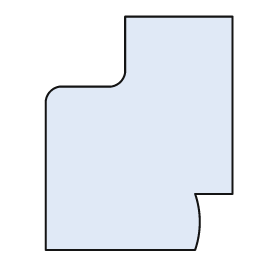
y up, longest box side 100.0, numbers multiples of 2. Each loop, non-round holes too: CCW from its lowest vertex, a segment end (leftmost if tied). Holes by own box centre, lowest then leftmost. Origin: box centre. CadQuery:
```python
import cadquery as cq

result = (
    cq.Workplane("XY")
    .moveTo(-40.0, -50.0)
    .lineTo(24.0, -50.0)
    .threePointArc((26.0, -38.0), (24.0, -26.0))
    .lineTo(40.0, -26.0)
    .lineTo(40.0, 50.0)
    .lineTo(-6.0, 50.0)
    .lineTo(-6.0, 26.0)
    .threePointArc((-8.0, 22.0), (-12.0, 20.0))
    .lineTo(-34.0, 20.0)
    .threePointArc((-38.0, 18.0), (-40.0, 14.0))
    .close()
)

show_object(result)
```